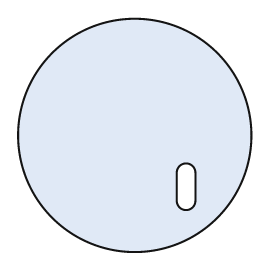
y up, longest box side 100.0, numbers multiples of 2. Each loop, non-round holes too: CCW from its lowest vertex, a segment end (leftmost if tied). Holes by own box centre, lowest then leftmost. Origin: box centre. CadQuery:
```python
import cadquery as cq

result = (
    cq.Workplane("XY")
    .moveTo(0.0, 0.0)
    .circle(50.0)
    .moveTo(18.0, -28.0)
    .threePointArc((22.0, -32.0), (26.0, -28.0))
    .lineTo(26.0, -16.0)
    .threePointArc((22.0, -12.0), (18.0, -16.0))
    .close()
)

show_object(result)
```